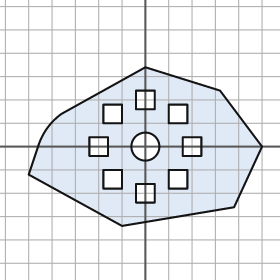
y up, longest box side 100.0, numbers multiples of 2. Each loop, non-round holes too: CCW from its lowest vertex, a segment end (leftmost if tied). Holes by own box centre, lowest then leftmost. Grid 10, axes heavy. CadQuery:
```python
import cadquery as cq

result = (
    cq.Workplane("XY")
    .moveTo(-10.0, -34.0)
    .lineTo(38.0, -26.0)
    .lineTo(50.0, 0.0)
    .lineTo(32.0, 24.0)
    .lineTo(0.0, 34.0)
    .lineTo(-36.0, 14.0)
    .threePointArc((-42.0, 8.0), (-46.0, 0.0))
    .lineTo(-50.0, -12.0)
    .close()
    .moveTo(-4.0, -24.0)
    .lineTo(4.0, -24.0)
    .lineTo(4.0, -16.0)
    .lineTo(-4.0, -16.0)
    .close()
    .moveTo(-18.0, -18.0)
    .lineTo(-10.0, -18.0)
    .lineTo(-10.0, -10.0)
    .lineTo(-18.0, -10.0)
    .close()
    .moveTo(10.0, -18.0)
    .lineTo(18.0, -18.0)
    .lineTo(18.0, -10.0)
    .lineTo(10.0, -10.0)
    .close()
    .moveTo(-24.0, -4.0)
    .lineTo(-16.0, -4.0)
    .lineTo(-16.0, 4.0)
    .lineTo(-24.0, 4.0)
    .close()
    .moveTo(0.0, 0.0)
    .circle(6.0)
    .moveTo(16.0, -4.0)
    .lineTo(24.0, -4.0)
    .lineTo(24.0, 4.0)
    .lineTo(16.0, 4.0)
    .close()
    .moveTo(-18.0, 10.0)
    .lineTo(-10.0, 10.0)
    .lineTo(-10.0, 18.0)
    .lineTo(-18.0, 18.0)
    .close()
    .moveTo(10.0, 10.0)
    .lineTo(18.0, 10.0)
    .lineTo(18.0, 18.0)
    .lineTo(10.0, 18.0)
    .close()
    .moveTo(-4.0, 16.0)
    .lineTo(4.0, 16.0)
    .lineTo(4.0, 24.0)
    .lineTo(-4.0, 24.0)
    .close()
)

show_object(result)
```